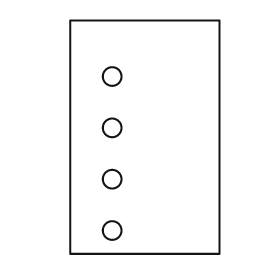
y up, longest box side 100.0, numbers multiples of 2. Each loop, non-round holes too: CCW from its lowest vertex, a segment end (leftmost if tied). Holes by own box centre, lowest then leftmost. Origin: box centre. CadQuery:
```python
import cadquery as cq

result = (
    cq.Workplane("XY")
    .moveTo(-32.0, -50.0)
    .lineTo(32.0, -50.0)
    .lineTo(32.0, 50.0)
    .lineTo(-32.0, 50.0)
    .close()
    .moveTo(-14.0, -40.0)
    .circle(4.0)
    .moveTo(-14.0, -18.0)
    .circle(4.0)
    .moveTo(-14.0, 4.0)
    .circle(4.0)
    .moveTo(-14.0, 26.0)
    .circle(4.0)
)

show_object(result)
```